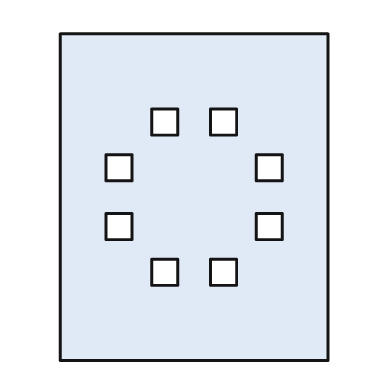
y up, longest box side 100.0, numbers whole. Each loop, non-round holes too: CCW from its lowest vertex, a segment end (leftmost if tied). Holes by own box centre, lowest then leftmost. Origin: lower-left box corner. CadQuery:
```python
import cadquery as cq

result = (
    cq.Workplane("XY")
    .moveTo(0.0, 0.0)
    .lineTo(82.0, 0.0)
    .lineTo(82.0, 100.0)
    .lineTo(0.0, 100.0)
    .close()
    .moveTo(28.0, 23.0)
    .lineTo(36.0, 23.0)
    .lineTo(36.0, 31.0)
    .lineTo(28.0, 31.0)
    .close()
    .moveTo(46.0, 23.0)
    .lineTo(54.0, 23.0)
    .lineTo(54.0, 31.0)
    .lineTo(46.0, 31.0)
    .close()
    .moveTo(14.0, 37.0)
    .lineTo(22.0, 37.0)
    .lineTo(22.0, 45.0)
    .lineTo(14.0, 45.0)
    .close()
    .moveTo(60.0, 37.0)
    .lineTo(68.0, 37.0)
    .lineTo(68.0, 45.0)
    .lineTo(60.0, 45.0)
    .close()
    .moveTo(14.0, 55.0)
    .lineTo(22.0, 55.0)
    .lineTo(22.0, 63.0)
    .lineTo(14.0, 63.0)
    .close()
    .moveTo(60.0, 55.0)
    .lineTo(68.0, 55.0)
    .lineTo(68.0, 63.0)
    .lineTo(60.0, 63.0)
    .close()
    .moveTo(28.0, 69.0)
    .lineTo(36.0, 69.0)
    .lineTo(36.0, 77.0)
    .lineTo(28.0, 77.0)
    .close()
    .moveTo(46.0, 69.0)
    .lineTo(54.0, 69.0)
    .lineTo(54.0, 77.0)
    .lineTo(46.0, 77.0)
    .close()
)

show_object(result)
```